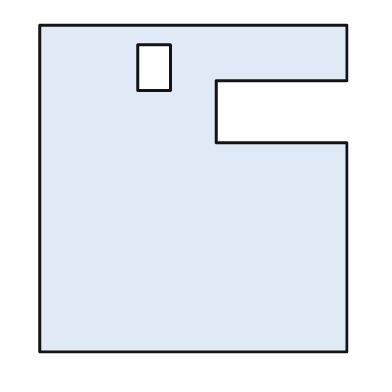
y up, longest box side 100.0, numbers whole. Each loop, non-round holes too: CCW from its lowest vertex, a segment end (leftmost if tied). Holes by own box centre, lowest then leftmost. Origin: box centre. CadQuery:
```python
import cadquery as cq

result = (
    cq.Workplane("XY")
    .moveTo(-47.0, -50.0)
    .lineTo(47.0, -50.0)
    .lineTo(47.0, 14.0)
    .lineTo(7.0, 14.0)
    .lineTo(7.0, 33.0)
    .lineTo(47.0, 33.0)
    .lineTo(47.0, 50.0)
    .lineTo(-47.0, 50.0)
    .close()
    .moveTo(-17.0, 30.0)
    .lineTo(-7.0, 30.0)
    .lineTo(-7.0, 44.0)
    .lineTo(-17.0, 44.0)
    .close()
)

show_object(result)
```